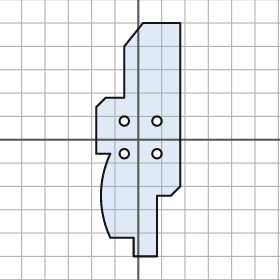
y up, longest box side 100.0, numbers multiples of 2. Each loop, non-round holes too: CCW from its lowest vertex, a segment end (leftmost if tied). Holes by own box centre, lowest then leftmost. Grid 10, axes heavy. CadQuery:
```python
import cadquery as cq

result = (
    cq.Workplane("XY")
    .moveTo(-2.0, -50.0)
    .lineTo(8.0, -50.0)
    .lineTo(8.0, -24.0)
    .lineTo(14.0, -24.0)
    .lineTo(18.0, -20.0)
    .lineTo(18.0, 50.0)
    .lineTo(2.0, 50.0)
    .lineTo(-6.0, 40.0)
    .lineTo(-6.0, 18.0)
    .lineTo(-14.0, 18.0)
    .lineTo(-18.0, 14.0)
    .lineTo(-18.0, -6.0)
    .lineTo(-12.0, -6.0)
    .threePointArc((-16.0, -24.0), (-12.0, -42.0))
    .lineTo(-2.0, -42.0)
    .close()
    .moveTo(-6.0, -6.0)
    .circle(2.0)
    .moveTo(8.0, -6.0)
    .circle(2.0)
    .moveTo(-6.0, 8.0)
    .circle(2.0)
    .moveTo(8.0, 8.0)
    .circle(2.0)
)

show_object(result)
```